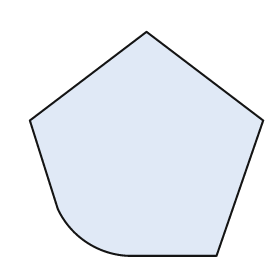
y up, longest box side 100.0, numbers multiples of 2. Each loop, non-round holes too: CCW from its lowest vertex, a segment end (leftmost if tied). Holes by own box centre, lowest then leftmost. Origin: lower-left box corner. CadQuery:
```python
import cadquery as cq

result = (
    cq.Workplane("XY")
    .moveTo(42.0, 0.0)
    .lineTo(80.0, 0.0)
    .lineTo(100.0, 58.0)
    .lineTo(50.0, 96.0)
    .lineTo(0.0, 58.0)
    .lineTo(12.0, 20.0)
    .threePointArc((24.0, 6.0), (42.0, 0.0))
    .close()
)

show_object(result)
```